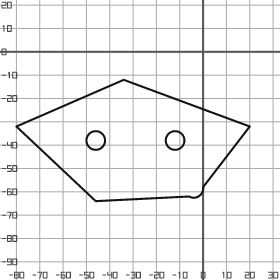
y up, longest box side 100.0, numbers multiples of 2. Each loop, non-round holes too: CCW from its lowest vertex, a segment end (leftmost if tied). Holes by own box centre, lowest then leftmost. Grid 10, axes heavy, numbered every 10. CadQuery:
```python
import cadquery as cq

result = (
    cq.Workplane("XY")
    .moveTo(-46.0, -64.0)
    .lineTo(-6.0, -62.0)
    .threePointArc((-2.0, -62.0), (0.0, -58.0))
    .lineTo(20.0, -32.0)
    .lineTo(-34.0, -12.0)
    .lineTo(-80.0, -32.0)
    .close()
    .moveTo(-46.0, -38.0)
    .circle(4.0)
    .moveTo(-12.0, -38.0)
    .circle(4.0)
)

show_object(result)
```